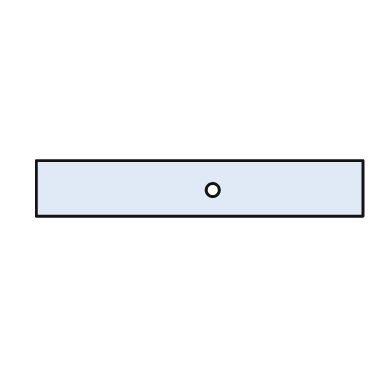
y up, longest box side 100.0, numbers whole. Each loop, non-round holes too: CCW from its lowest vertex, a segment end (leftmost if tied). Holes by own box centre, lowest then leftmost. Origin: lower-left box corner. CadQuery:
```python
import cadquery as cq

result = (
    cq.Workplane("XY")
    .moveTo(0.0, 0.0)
    .lineTo(100.0, 0.0)
    .lineTo(100.0, 17.0)
    .lineTo(0.0, 17.0)
    .close()
    .moveTo(54.0, 8.0)
    .circle(2.0)
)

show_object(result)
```